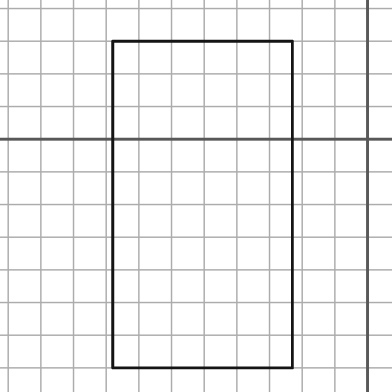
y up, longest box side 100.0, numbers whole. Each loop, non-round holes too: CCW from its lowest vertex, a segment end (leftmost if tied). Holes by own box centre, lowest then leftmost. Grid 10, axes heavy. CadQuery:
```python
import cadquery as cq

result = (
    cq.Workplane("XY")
    .moveTo(-78.0, -70.0)
    .lineTo(-23.0, -70.0)
    .lineTo(-23.0, 30.0)
    .lineTo(-78.0, 30.0)
    .close()
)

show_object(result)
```